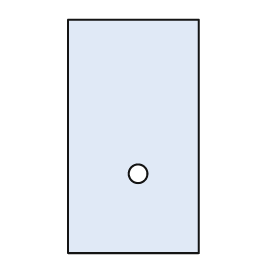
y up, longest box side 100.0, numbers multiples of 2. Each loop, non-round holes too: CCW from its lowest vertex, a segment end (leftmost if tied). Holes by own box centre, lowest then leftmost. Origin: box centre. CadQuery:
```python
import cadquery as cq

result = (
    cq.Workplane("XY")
    .moveTo(-28.0, -50.0)
    .lineTo(28.0, -50.0)
    .lineTo(28.0, 50.0)
    .lineTo(-28.0, 50.0)
    .close()
    .moveTo(2.0, -16.0)
    .circle(4.0)
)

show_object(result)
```